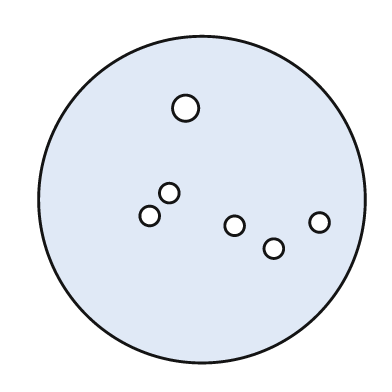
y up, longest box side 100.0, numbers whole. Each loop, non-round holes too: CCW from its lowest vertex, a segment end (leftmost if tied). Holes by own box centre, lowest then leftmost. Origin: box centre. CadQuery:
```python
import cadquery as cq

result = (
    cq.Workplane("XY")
    .moveTo(0.0, 0.0)
    .circle(50.0)
    .moveTo(22.0, -15.0)
    .circle(3.0)
    .moveTo(10.0, -8.0)
    .circle(3.0)
    .moveTo(36.0, -7.0)
    .circle(3.0)
    .moveTo(-16.0, -5.0)
    .circle(3.0)
    .moveTo(-10.0, 2.0)
    .circle(3.0)
    .moveTo(-5.0, 28.0)
    .circle(4.0)
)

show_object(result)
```